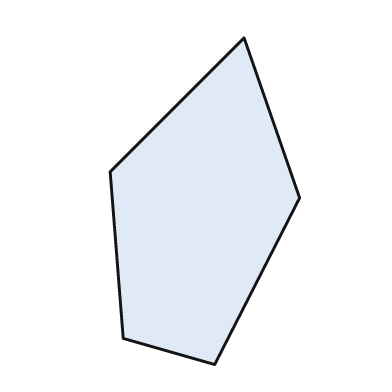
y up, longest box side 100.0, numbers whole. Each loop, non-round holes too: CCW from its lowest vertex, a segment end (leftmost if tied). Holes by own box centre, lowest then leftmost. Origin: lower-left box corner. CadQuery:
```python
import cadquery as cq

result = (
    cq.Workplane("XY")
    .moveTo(32.0, 0.0)
    .lineTo(58.0, 51.0)
    .lineTo(41.0, 100.0)
    .lineTo(0.0, 59.0)
    .lineTo(4.0, 8.0)
    .close()
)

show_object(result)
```